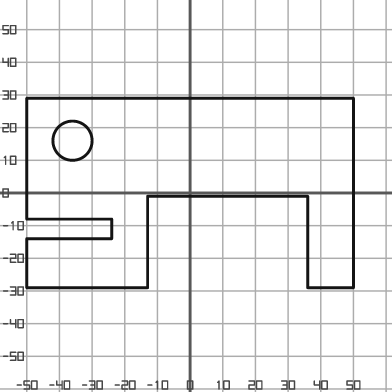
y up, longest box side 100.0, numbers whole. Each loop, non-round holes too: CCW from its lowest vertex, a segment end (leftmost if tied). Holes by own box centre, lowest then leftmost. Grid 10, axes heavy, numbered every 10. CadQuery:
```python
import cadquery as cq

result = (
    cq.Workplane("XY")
    .moveTo(-50.0, -29.0)
    .lineTo(-13.0, -29.0)
    .lineTo(-13.0, -1.0)
    .lineTo(36.0, -1.0)
    .lineTo(36.0, -29.0)
    .lineTo(50.0, -29.0)
    .lineTo(50.0, 29.0)
    .lineTo(-50.0, 29.0)
    .lineTo(-50.0, -8.0)
    .lineTo(-24.0, -8.0)
    .lineTo(-24.0, -14.0)
    .lineTo(-50.0, -14.0)
    .close()
    .moveTo(-36.0, 16.0)
    .circle(6.0)
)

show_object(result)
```